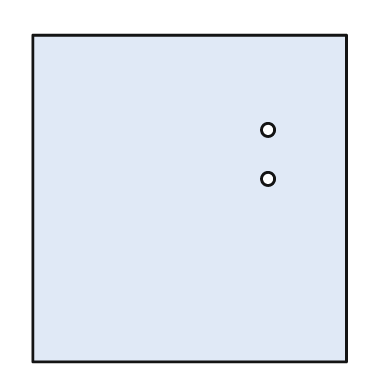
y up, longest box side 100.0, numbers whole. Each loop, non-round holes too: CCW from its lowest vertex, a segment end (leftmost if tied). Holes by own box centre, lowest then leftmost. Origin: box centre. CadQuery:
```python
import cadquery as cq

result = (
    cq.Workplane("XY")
    .moveTo(-48.0, -50.0)
    .lineTo(48.0, -50.0)
    .lineTo(48.0, 50.0)
    .lineTo(-48.0, 50.0)
    .close()
    .moveTo(24.0, 6.0)
    .circle(2.0)
    .moveTo(24.0, 21.0)
    .circle(2.0)
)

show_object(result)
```